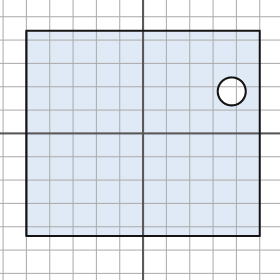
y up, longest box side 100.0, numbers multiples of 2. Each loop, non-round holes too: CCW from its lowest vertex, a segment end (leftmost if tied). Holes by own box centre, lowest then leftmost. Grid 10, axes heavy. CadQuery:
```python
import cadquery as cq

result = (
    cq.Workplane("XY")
    .moveTo(-50.0, -44.0)
    .lineTo(50.0, -44.0)
    .lineTo(50.0, 44.0)
    .lineTo(-50.0, 44.0)
    .close()
    .moveTo(38.0, 18.0)
    .circle(6.0)
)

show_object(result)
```